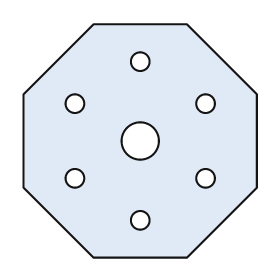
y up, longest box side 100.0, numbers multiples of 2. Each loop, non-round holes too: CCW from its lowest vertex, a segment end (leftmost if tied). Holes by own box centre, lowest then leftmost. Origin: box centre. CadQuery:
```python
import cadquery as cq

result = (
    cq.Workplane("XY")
    .moveTo(-20.0, -50.0)
    .lineTo(20.0, -50.0)
    .lineTo(50.0, -20.0)
    .lineTo(50.0, 20.0)
    .lineTo(20.0, 50.0)
    .lineTo(-20.0, 50.0)
    .lineTo(-50.0, 20.0)
    .lineTo(-50.0, -20.0)
    .close()
    .moveTo(0.0, -34.0)
    .circle(4.0)
    .moveTo(-28.0, -16.0)
    .circle(4.0)
    .moveTo(28.0, -16.0)
    .circle(4.0)
    .moveTo(0.0, 0.0)
    .circle(8.0)
    .moveTo(-28.0, 16.0)
    .circle(4.0)
    .moveTo(28.0, 16.0)
    .circle(4.0)
    .moveTo(0.0, 34.0)
    .circle(4.0)
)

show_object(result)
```